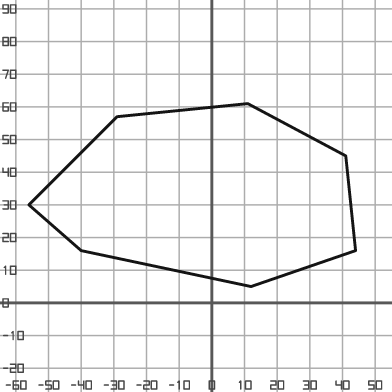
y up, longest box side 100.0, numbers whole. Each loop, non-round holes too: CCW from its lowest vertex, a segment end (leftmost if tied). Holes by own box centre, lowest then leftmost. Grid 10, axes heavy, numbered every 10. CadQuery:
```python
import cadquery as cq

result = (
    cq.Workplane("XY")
    .moveTo(12.0, 5.0)
    .lineTo(44.0, 16.0)
    .lineTo(41.0, 45.0)
    .lineTo(11.0, 61.0)
    .lineTo(-29.0, 57.0)
    .lineTo(-56.0, 30.0)
    .lineTo(-40.0, 16.0)
    .close()
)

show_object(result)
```